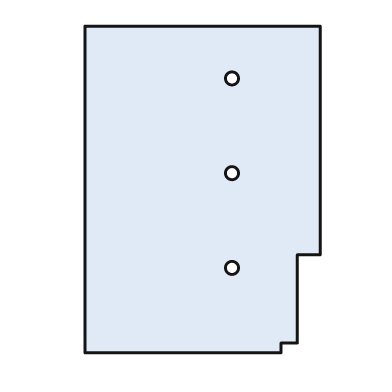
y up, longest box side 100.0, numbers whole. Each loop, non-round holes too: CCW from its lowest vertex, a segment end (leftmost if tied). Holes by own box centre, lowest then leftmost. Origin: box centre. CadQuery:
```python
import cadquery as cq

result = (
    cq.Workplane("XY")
    .moveTo(-36.0, -50.0)
    .lineTo(24.0, -50.0)
    .lineTo(24.0, -47.0)
    .lineTo(29.0, -47.0)
    .lineTo(29.0, -20.0)
    .lineTo(36.0, -20.0)
    .lineTo(36.0, 50.0)
    .lineTo(-36.0, 50.0)
    .close()
    .moveTo(9.0, -24.0)
    .circle(2.0)
    .moveTo(9.0, 5.0)
    .circle(2.0)
    .moveTo(9.0, 34.0)
    .circle(2.0)
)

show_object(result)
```